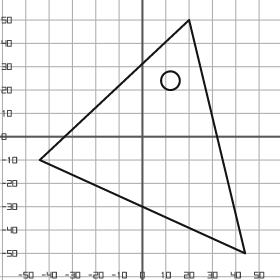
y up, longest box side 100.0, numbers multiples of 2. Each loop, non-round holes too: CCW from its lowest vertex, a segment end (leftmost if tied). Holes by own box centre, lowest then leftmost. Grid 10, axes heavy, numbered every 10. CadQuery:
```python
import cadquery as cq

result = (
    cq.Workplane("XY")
    .moveTo(44.0, -50.0)
    .lineTo(20.0, 50.0)
    .lineTo(-44.0, -10.0)
    .close()
    .moveTo(12.0, 24.0)
    .circle(4.0)
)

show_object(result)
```